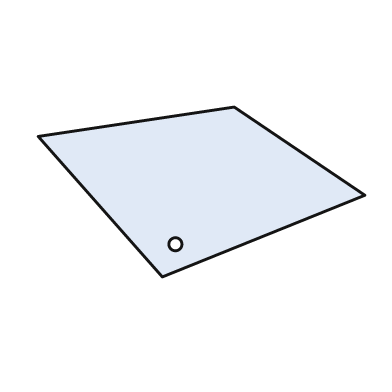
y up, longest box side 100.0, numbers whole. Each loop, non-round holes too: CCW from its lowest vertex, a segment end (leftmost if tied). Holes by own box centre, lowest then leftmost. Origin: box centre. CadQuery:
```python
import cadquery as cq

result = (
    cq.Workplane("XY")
    .moveTo(-12.0, -26.0)
    .lineTo(50.0, -1.0)
    .lineTo(10.0, 26.0)
    .lineTo(-50.0, 17.0)
    .close()
    .moveTo(-8.0, -16.0)
    .circle(2.0)
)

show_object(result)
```